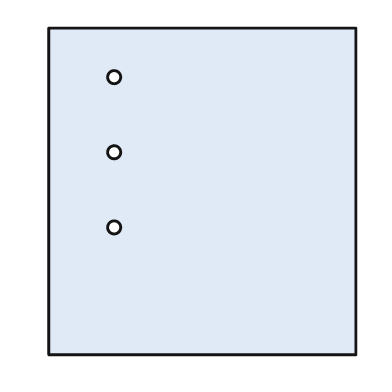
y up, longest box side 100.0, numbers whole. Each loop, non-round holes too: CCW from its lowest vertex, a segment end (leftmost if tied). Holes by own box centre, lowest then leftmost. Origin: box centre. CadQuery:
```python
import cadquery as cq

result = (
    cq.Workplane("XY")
    .moveTo(-47.0, -50.0)
    .lineTo(47.0, -50.0)
    .lineTo(47.0, 50.0)
    .lineTo(-47.0, 50.0)
    .close()
    .moveTo(-27.0, -11.0)
    .circle(2.0)
    .moveTo(-27.0, 12.0)
    .circle(2.0)
    .moveTo(-27.0, 35.0)
    .circle(2.0)
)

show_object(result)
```